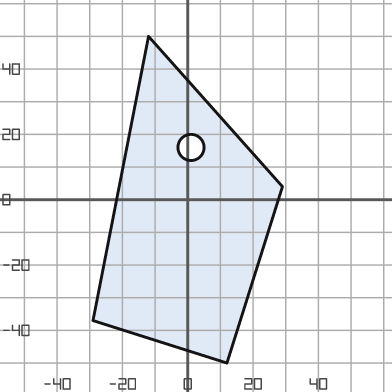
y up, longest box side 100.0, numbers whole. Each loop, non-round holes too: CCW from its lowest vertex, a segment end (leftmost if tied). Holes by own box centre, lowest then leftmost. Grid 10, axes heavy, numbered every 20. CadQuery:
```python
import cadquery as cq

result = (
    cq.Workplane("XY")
    .moveTo(12.0, -50.0)
    .lineTo(29.0, 4.0)
    .lineTo(-12.0, 50.0)
    .lineTo(-29.0, -37.0)
    .close()
    .moveTo(1.0, 16.0)
    .circle(4.0)
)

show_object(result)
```